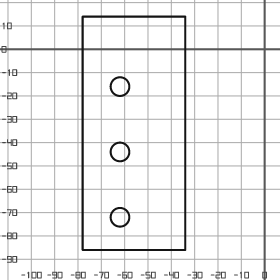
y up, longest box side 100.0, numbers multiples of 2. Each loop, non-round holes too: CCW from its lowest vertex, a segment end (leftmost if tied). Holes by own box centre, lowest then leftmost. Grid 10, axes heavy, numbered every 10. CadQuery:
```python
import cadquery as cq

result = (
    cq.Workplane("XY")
    .moveTo(-78.0, -86.0)
    .lineTo(-34.0, -86.0)
    .lineTo(-34.0, 14.0)
    .lineTo(-78.0, 14.0)
    .close()
    .moveTo(-62.0, -72.0)
    .circle(4.0)
    .moveTo(-62.0, -44.0)
    .circle(4.0)
    .moveTo(-62.0, -16.0)
    .circle(4.0)
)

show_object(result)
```